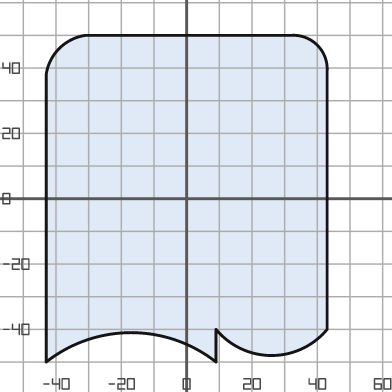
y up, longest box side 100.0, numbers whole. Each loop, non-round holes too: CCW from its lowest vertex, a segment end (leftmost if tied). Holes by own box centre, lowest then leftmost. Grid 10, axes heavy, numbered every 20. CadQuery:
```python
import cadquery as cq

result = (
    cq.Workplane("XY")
    .moveTo(-43.0, -50.0)
    .threePointArc((-17.0, -41.0), (9.0, -50.0))
    .lineTo(9.0, -40.0)
    .threePointArc((26.0, -48.0), (43.0, -40.0))
    .lineTo(43.0, 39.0)
    .threePointArc((40.0, 47.0), (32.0, 50.0))
    .lineTo(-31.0, 50.0)
    .threePointArc((-39.0, 46.0), (-43.0, 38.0))
    .close()
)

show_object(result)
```